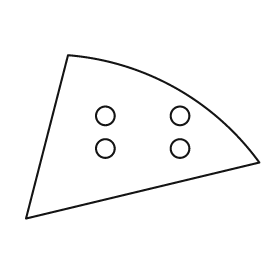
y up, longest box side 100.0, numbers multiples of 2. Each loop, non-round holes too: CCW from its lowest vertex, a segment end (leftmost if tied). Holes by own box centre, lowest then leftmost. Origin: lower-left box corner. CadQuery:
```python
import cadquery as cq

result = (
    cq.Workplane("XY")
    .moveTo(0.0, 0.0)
    .lineTo(100.0, 24.0)
    .threePointArc((64.0, 56.0), (18.0, 70.0))
    .close()
    .moveTo(34.0, 30.0)
    .circle(4.0)
    .moveTo(66.0, 30.0)
    .circle(4.0)
    .moveTo(34.0, 44.0)
    .circle(4.0)
    .moveTo(66.0, 44.0)
    .circle(4.0)
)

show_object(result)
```